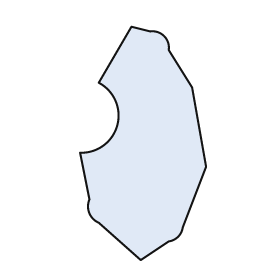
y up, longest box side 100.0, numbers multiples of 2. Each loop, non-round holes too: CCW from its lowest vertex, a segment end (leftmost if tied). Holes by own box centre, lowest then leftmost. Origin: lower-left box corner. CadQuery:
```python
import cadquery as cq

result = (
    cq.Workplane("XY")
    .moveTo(26.0, 0.0)
    .lineTo(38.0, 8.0)
    .threePointArc((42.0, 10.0), (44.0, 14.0))
    .lineTo(54.0, 40.0)
    .lineTo(48.0, 74.0)
    .lineTo(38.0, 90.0)
    .threePointArc((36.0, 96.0), (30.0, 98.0))
    .lineTo(22.0, 100.0)
    .lineTo(8.0, 76.0)
    .threePointArc((16.0, 58.0), (0.0, 46.0))
    .lineTo(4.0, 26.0)
    .threePointArc((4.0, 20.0), (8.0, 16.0))
    .close()
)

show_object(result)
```